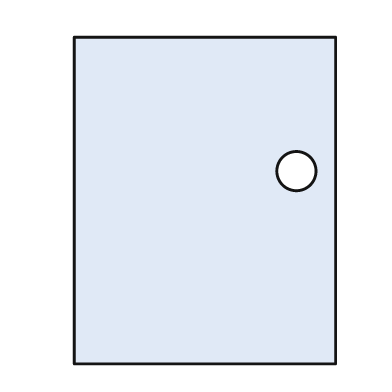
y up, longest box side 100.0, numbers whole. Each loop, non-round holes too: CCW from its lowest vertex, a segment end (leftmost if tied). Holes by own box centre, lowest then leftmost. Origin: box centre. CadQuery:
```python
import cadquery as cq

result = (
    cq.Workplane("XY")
    .moveTo(-40.0, -50.0)
    .lineTo(40.0, -50.0)
    .lineTo(40.0, 50.0)
    .lineTo(-40.0, 50.0)
    .close()
    .moveTo(28.0, 9.0)
    .circle(6.0)
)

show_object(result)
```